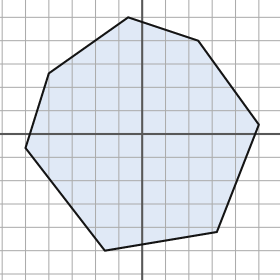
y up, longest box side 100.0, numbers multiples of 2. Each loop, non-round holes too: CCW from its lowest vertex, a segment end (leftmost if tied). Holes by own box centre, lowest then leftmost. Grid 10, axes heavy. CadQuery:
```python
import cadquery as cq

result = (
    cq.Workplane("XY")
    .moveTo(-16.0, -50.0)
    .lineTo(32.0, -42.0)
    .lineTo(50.0, 4.0)
    .lineTo(24.0, 40.0)
    .lineTo(-6.0, 50.0)
    .lineTo(-40.0, 26.0)
    .lineTo(-50.0, -6.0)
    .close()
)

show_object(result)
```